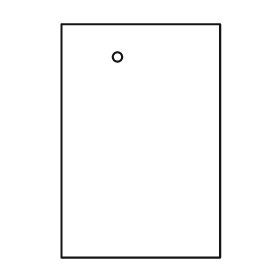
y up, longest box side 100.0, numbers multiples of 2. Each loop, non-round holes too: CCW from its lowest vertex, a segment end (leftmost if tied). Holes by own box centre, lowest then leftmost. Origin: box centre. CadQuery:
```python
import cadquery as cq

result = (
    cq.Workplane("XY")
    .moveTo(-34.0, -50.0)
    .lineTo(34.0, -50.0)
    .lineTo(34.0, 50.0)
    .lineTo(-34.0, 50.0)
    .close()
    .moveTo(-10.0, 36.0)
    .circle(2.0)
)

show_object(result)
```